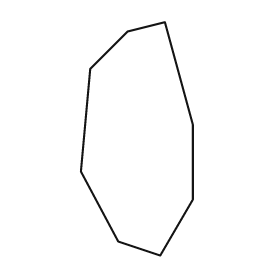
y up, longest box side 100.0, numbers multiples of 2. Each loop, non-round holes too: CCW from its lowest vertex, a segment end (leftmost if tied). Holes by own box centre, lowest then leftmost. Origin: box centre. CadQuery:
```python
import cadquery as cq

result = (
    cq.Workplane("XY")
    .moveTo(10.0, -50.0)
    .lineTo(24.0, -26.0)
    .lineTo(24.0, 6.0)
    .lineTo(12.0, 50.0)
    .lineTo(-4.0, 46.0)
    .lineTo(-20.0, 30.0)
    .lineTo(-24.0, -14.0)
    .lineTo(-8.0, -44.0)
    .close()
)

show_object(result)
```